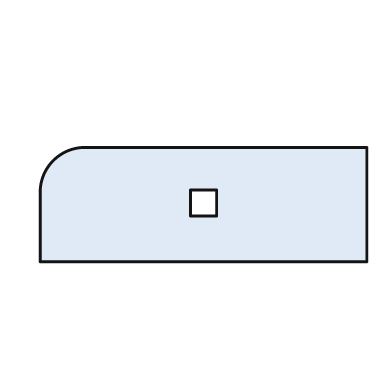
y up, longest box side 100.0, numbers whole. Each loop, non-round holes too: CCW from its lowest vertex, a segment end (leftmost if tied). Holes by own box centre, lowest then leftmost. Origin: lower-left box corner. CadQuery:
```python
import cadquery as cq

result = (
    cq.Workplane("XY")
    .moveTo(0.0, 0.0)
    .lineTo(100.0, 0.0)
    .lineTo(100.0, 35.0)
    .lineTo(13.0, 35.0)
    .threePointArc((4.0, 31.0), (0.0, 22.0))
    .close()
    .moveTo(46.0, 14.0)
    .lineTo(54.0, 14.0)
    .lineTo(54.0, 22.0)
    .lineTo(46.0, 22.0)
    .close()
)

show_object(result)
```